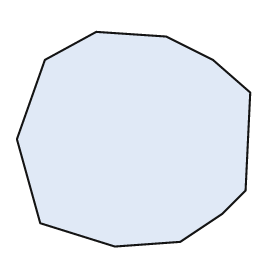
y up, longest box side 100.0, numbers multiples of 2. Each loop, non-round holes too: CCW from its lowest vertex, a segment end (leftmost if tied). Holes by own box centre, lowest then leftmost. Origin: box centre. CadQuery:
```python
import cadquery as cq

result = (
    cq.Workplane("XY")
    .moveTo(-8.0, -46.0)
    .lineTo(20.0, -44.0)
    .lineTo(38.0, -32.0)
    .lineTo(48.0, -22.0)
    .lineTo(50.0, 20.0)
    .lineTo(34.0, 34.0)
    .lineTo(14.0, 44.0)
    .lineTo(-16.0, 46.0)
    .lineTo(-38.0, 34.0)
    .lineTo(-50.0, 0.0)
    .lineTo(-40.0, -36.0)
    .close()
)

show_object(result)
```